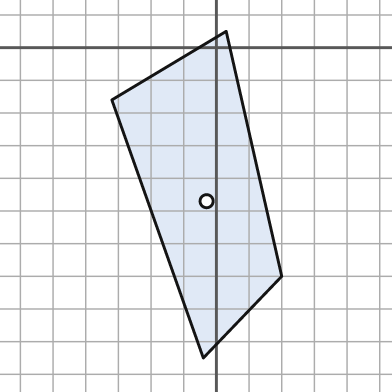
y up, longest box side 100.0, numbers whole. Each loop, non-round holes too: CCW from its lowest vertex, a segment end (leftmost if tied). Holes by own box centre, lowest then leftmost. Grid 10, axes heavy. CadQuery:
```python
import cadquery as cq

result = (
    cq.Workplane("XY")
    .moveTo(-4.0, -95.0)
    .lineTo(20.0, -70.0)
    .lineTo(3.0, 5.0)
    .lineTo(-32.0, -16.0)
    .close()
    .moveTo(-3.0, -47.0)
    .circle(2.0)
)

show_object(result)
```